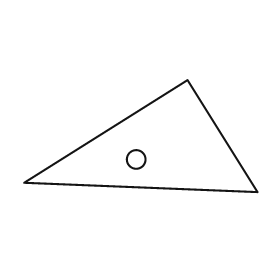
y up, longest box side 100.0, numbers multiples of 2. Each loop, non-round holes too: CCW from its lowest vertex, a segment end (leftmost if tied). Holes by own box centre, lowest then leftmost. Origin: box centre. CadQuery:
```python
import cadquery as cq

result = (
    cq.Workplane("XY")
    .moveTo(50.0, -24.0)
    .lineTo(20.0, 24.0)
    .lineTo(-50.0, -20.0)
    .close()
    .moveTo(-2.0, -10.0)
    .circle(4.0)
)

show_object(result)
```